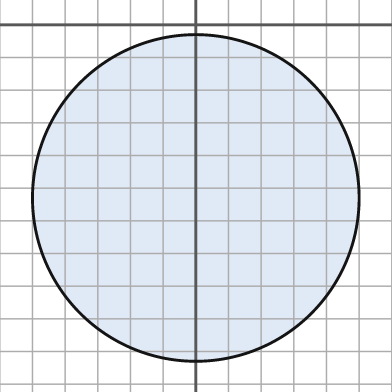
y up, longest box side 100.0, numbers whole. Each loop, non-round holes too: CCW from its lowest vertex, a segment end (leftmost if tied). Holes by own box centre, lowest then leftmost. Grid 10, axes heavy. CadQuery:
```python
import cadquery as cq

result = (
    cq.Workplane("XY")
    .moveTo(0.0, -53.0)
    .circle(50.0)
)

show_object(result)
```